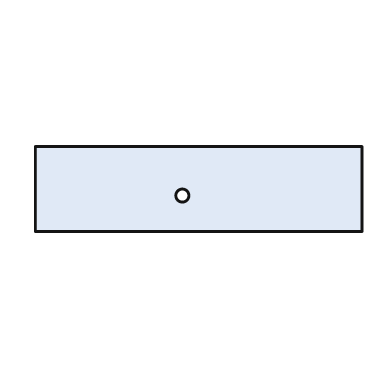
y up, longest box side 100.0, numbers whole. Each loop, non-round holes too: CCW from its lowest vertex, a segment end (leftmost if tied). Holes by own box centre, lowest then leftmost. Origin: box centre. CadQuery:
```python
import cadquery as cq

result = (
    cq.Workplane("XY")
    .moveTo(-50.0, -13.0)
    .lineTo(50.0, -13.0)
    .lineTo(50.0, 13.0)
    .lineTo(-50.0, 13.0)
    .close()
    .moveTo(-5.0, -2.0)
    .circle(2.0)
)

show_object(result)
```